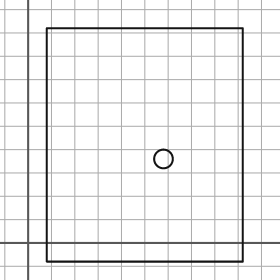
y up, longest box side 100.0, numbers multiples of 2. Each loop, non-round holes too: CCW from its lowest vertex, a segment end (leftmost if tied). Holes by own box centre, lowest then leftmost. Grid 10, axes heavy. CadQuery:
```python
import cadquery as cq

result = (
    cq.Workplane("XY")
    .moveTo(8.0, -8.0)
    .lineTo(92.0, -8.0)
    .lineTo(92.0, 92.0)
    .lineTo(8.0, 92.0)
    .close()
    .moveTo(58.0, 36.0)
    .circle(4.0)
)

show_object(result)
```